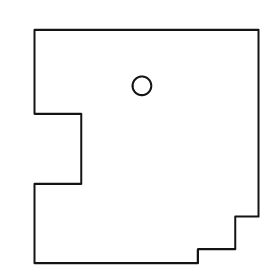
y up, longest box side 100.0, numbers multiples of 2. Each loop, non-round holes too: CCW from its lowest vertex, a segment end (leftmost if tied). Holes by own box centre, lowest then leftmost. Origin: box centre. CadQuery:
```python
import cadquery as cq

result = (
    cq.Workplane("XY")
    .moveTo(-48.0, -50.0)
    .lineTo(22.0, -50.0)
    .lineTo(22.0, -44.0)
    .lineTo(38.0, -44.0)
    .lineTo(38.0, -30.0)
    .lineTo(48.0, -30.0)
    .lineTo(48.0, 50.0)
    .lineTo(-48.0, 50.0)
    .lineTo(-48.0, 14.0)
    .lineTo(-28.0, 14.0)
    .lineTo(-28.0, -16.0)
    .lineTo(-48.0, -16.0)
    .close()
    .moveTo(-2.0, 26.0)
    .circle(4.0)
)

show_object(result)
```